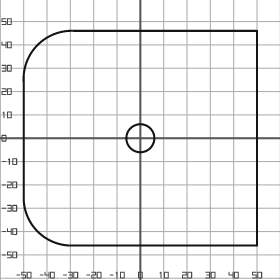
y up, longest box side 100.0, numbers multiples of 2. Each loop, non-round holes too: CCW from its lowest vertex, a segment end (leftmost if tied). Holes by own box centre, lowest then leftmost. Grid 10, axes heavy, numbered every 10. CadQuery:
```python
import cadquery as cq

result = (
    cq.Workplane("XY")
    .moveTo(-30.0, -46.0)
    .lineTo(50.0, -46.0)
    .lineTo(50.0, 46.0)
    .lineTo(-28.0, 46.0)
    .threePointArc((-44.0, 40.0), (-50.0, 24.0))
    .lineTo(-50.0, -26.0)
    .threePointArc((-44.0, -40.0), (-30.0, -46.0))
    .close()
    .moveTo(0.0, 0.0)
    .circle(6.0)
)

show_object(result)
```